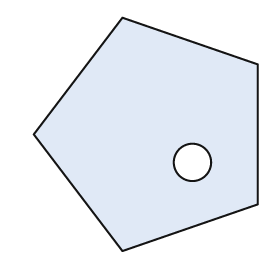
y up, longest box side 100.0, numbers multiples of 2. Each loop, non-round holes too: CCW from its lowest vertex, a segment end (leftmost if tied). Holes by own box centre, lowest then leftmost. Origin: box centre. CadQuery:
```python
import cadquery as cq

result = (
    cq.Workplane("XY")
    .moveTo(-10.0, -50.0)
    .lineTo(48.0, -30.0)
    .lineTo(48.0, 30.0)
    .lineTo(-10.0, 50.0)
    .lineTo(-48.0, 0.0)
    .close()
    .moveTo(20.0, -12.0)
    .circle(8.0)
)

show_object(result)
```